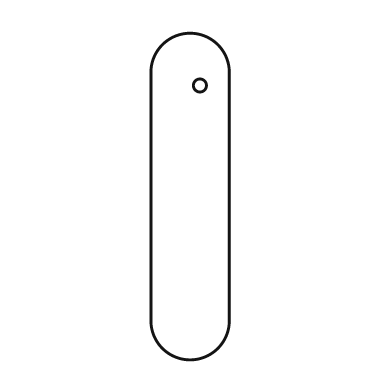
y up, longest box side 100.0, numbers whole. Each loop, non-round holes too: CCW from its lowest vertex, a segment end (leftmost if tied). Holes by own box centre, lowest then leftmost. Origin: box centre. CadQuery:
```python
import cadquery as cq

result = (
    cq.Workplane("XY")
    .moveTo(-12.0, -38.0)
    .threePointArc((0.0, -50.0), (12.0, -38.0))
    .lineTo(12.0, 38.0)
    .threePointArc((0.0, 50.0), (-12.0, 38.0))
    .close()
    .moveTo(3.0, 34.0)
    .circle(2.0)
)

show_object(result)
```